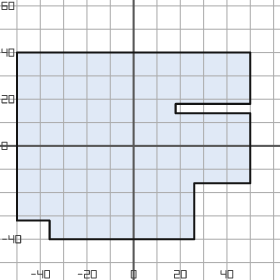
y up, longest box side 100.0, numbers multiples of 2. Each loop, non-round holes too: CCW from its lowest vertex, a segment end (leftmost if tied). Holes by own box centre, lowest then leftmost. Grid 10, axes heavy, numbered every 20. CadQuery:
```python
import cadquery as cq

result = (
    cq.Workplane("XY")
    .moveTo(-36.0, -40.0)
    .lineTo(26.0, -40.0)
    .lineTo(26.0, -16.0)
    .lineTo(50.0, -16.0)
    .lineTo(50.0, 14.0)
    .lineTo(18.0, 14.0)
    .lineTo(18.0, 18.0)
    .lineTo(50.0, 18.0)
    .lineTo(50.0, 40.0)
    .lineTo(-50.0, 40.0)
    .lineTo(-50.0, -32.0)
    .lineTo(-36.0, -32.0)
    .close()
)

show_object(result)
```